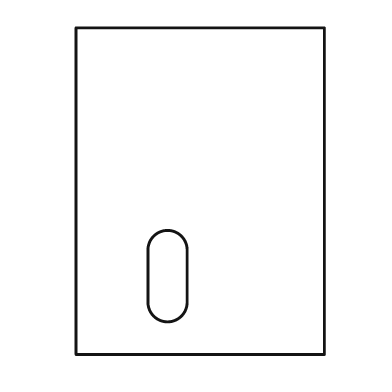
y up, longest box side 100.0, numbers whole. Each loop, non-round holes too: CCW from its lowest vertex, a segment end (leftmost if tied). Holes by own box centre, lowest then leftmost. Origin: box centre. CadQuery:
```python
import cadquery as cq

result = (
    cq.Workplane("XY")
    .moveTo(-38.0, -50.0)
    .lineTo(38.0, -50.0)
    .lineTo(38.0, 50.0)
    .lineTo(-38.0, 50.0)
    .close()
    .moveTo(-16.0, -34.0)
    .threePointArc((-10.0, -40.0), (-4.0, -34.0))
    .lineTo(-4.0, -18.0)
    .threePointArc((-10.0, -12.0), (-16.0, -18.0))
    .close()
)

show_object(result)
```